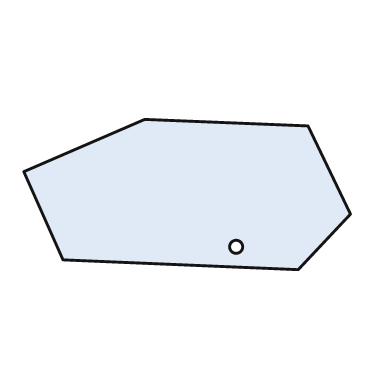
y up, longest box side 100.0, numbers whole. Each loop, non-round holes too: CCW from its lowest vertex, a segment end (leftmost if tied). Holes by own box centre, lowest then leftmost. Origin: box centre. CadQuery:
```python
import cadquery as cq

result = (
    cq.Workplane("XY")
    .moveTo(34.0, -23.0)
    .lineTo(50.0, -6.0)
    .lineTo(37.0, 21.0)
    .lineTo(-13.0, 23.0)
    .lineTo(-50.0, 7.0)
    .lineTo(-38.0, -20.0)
    .close()
    .moveTo(15.0, -16.0)
    .circle(2.0)
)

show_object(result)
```